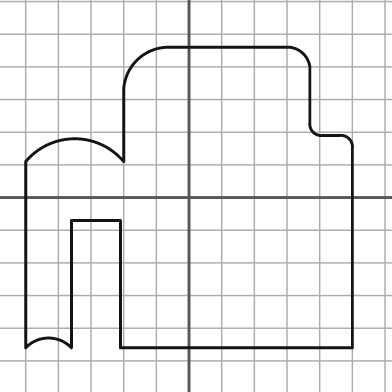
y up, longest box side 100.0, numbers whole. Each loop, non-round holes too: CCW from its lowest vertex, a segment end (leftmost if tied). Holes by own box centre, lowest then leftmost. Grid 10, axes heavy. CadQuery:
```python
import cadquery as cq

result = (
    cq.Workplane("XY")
    .moveTo(-50.0, -46.0)
    .threePointArc((-43.0, -43.0), (-36.0, -46.0))
    .lineTo(-36.0, -7.0)
    .lineTo(-21.0, -7.0)
    .lineTo(-21.0, -46.0)
    .lineTo(50.0, -46.0)
    .lineTo(50.0, 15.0)
    .threePointArc((49.0, 18.0), (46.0, 19.0))
    .lineTo(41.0, 19.0)
    .threePointArc((38.0, 20.0), (37.0, 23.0))
    .lineTo(37.0, 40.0)
    .threePointArc((35.0, 44.0), (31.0, 46.0))
    .lineTo(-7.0, 46.0)
    .threePointArc((-16.0, 42.0), (-20.0, 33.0))
    .lineTo(-20.0, 11.0)
    .threePointArc((-35.0, 18.0), (-50.0, 11.0))
    .close()
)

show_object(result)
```